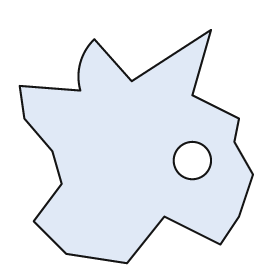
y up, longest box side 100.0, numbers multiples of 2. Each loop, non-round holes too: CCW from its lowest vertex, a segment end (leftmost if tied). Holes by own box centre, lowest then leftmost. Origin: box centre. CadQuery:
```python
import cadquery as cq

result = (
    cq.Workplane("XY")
    .moveTo(-4.0, -50.0)
    .lineTo(12.0, -30.0)
    .lineTo(36.0, -42.0)
    .lineTo(44.0, -30.0)
    .lineTo(50.0, -12.0)
    .lineTo(42.0, 2.0)
    .lineTo(44.0, 12.0)
    .lineTo(24.0, 22.0)
    .lineTo(32.0, 50.0)
    .lineTo(-2.0, 28.0)
    .lineTo(-18.0, 46.0)
    .threePointArc((-24.0, 36.0), (-24.0, 24.0))
    .lineTo(-50.0, 26.0)
    .lineTo(-48.0, 12.0)
    .lineTo(-36.0, -2.0)
    .lineTo(-32.0, -16.0)
    .lineTo(-44.0, -32.0)
    .lineTo(-30.0, -46.0)
    .close()
    .moveTo(24.0, -6.0)
    .circle(8.0)
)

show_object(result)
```